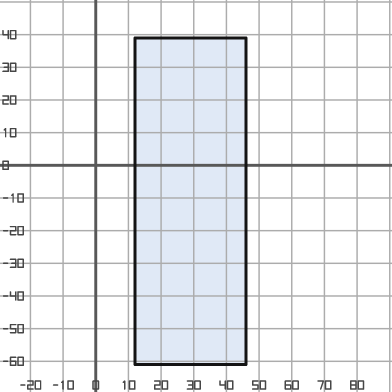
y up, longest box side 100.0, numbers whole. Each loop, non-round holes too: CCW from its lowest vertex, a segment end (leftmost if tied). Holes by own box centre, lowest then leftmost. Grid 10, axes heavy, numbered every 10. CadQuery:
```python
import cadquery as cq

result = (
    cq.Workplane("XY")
    .moveTo(12.0, -61.0)
    .lineTo(46.0, -61.0)
    .lineTo(46.0, 39.0)
    .lineTo(12.0, 39.0)
    .close()
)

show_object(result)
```